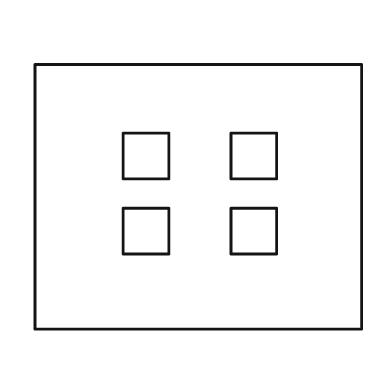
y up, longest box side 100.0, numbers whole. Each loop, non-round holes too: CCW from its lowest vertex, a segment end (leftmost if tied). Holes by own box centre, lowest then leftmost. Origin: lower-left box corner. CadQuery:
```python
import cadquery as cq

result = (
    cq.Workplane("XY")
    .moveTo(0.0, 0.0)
    .lineTo(100.0, 0.0)
    .lineTo(100.0, 81.0)
    .lineTo(0.0, 81.0)
    .close()
    .moveTo(27.0, 23.0)
    .lineTo(41.0, 23.0)
    .lineTo(41.0, 37.0)
    .lineTo(27.0, 37.0)
    .close()
    .moveTo(60.0, 23.0)
    .lineTo(74.0, 23.0)
    .lineTo(74.0, 37.0)
    .lineTo(60.0, 37.0)
    .close()
    .moveTo(27.0, 46.0)
    .lineTo(41.0, 46.0)
    .lineTo(41.0, 60.0)
    .lineTo(27.0, 60.0)
    .close()
    .moveTo(60.0, 46.0)
    .lineTo(74.0, 46.0)
    .lineTo(74.0, 60.0)
    .lineTo(60.0, 60.0)
    .close()
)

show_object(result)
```